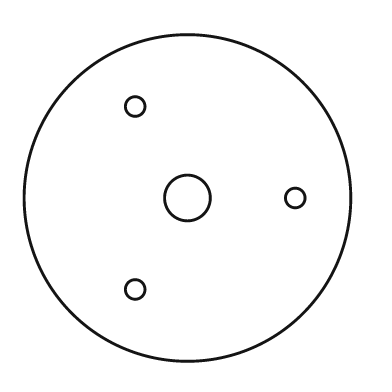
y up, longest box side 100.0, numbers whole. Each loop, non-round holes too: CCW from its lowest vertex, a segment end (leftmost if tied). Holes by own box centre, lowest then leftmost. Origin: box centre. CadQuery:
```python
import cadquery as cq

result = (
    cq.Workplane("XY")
    .moveTo(0.0, 0.0)
    .circle(50.0)
    .moveTo(-16.0, -28.0)
    .circle(3.0)
    .moveTo(0.0, 0.0)
    .circle(7.0)
    .moveTo(33.0, 0.0)
    .circle(3.0)
    .moveTo(-16.0, 28.0)
    .circle(3.0)
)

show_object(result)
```